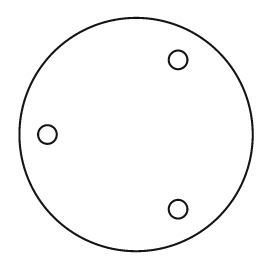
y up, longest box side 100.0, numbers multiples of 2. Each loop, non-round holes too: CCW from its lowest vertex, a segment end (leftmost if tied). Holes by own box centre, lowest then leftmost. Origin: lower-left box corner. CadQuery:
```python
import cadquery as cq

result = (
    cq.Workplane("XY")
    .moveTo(50.0, 50.0)
    .circle(50.0)
    .moveTo(68.0, 18.0)
    .circle(4.0)
    .moveTo(12.0, 50.0)
    .circle(4.0)
    .moveTo(68.0, 82.0)
    .circle(4.0)
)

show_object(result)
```